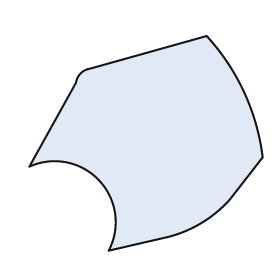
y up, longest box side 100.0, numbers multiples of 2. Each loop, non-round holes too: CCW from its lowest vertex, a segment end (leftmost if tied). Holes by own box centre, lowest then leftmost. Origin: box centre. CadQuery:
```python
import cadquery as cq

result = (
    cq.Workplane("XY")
    .moveTo(-16.0, -46.0)
    .lineTo(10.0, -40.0)
    .threePointArc((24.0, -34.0), (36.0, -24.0))
    .lineTo(50.0, -6.0)
    .threePointArc((42.0, 22.0), (26.0, 46.0))
    .lineTo(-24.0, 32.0)
    .threePointArc((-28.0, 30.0), (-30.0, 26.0))
    .lineTo(-50.0, -10.0)
    .threePointArc((-20.0, -16.0), (-16.0, -46.0))
    .close()
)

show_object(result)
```